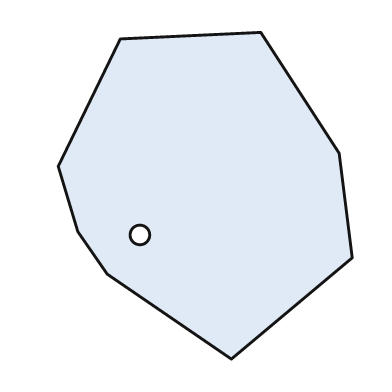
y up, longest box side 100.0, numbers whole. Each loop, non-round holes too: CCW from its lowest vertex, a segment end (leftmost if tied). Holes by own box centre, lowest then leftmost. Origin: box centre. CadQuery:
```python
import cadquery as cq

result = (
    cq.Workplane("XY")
    .moveTo(8.0, -50.0)
    .lineTo(45.0, -19.0)
    .lineTo(41.0, 13.0)
    .lineTo(17.0, 50.0)
    .lineTo(-26.0, 48.0)
    .lineTo(-45.0, 9.0)
    .lineTo(-39.0, -11.0)
    .lineTo(-30.0, -24.0)
    .close()
    .moveTo(-20.0, -12.0)
    .circle(3.0)
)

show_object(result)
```